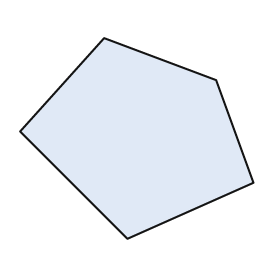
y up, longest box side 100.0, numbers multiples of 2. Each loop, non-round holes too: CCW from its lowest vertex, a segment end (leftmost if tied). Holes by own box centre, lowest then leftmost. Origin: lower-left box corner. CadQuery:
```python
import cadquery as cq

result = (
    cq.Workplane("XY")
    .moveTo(46.0, 0.0)
    .lineTo(100.0, 24.0)
    .lineTo(84.0, 68.0)
    .lineTo(36.0, 86.0)
    .lineTo(0.0, 46.0)
    .close()
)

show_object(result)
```